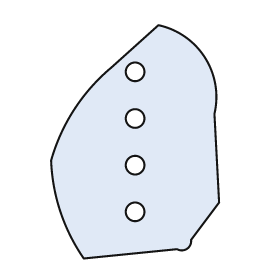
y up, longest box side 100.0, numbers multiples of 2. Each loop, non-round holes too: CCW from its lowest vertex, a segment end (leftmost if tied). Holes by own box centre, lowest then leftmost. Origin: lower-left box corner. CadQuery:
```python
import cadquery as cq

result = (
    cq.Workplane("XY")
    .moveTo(14.0, 0.0)
    .lineTo(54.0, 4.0)
    .threePointArc((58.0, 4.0), (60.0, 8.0))
    .lineTo(72.0, 24.0)
    .lineTo(70.0, 62.0)
    .threePointArc((66.0, 86.0), (46.0, 100.0))
    .lineTo(26.0, 82.0)
    .threePointArc((10.0, 64.0), (0.0, 42.0))
    .threePointArc((4.0, 20.0), (14.0, 0.0))
    .close()
    .moveTo(36.0, 20.0)
    .circle(4.0)
    .moveTo(36.0, 40.0)
    .circle(4.0)
    .moveTo(36.0, 60.0)
    .circle(4.0)
    .moveTo(36.0, 80.0)
    .circle(4.0)
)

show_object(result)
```